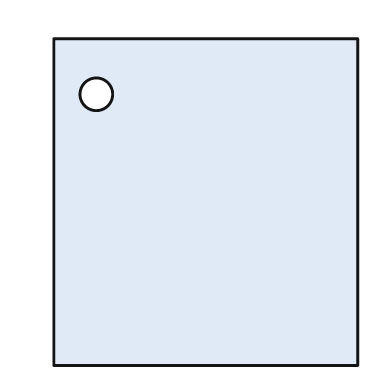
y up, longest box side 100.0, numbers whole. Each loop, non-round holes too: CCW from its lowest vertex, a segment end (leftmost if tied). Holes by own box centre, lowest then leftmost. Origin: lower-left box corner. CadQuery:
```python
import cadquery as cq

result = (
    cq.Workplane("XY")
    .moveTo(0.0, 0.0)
    .lineTo(93.0, 0.0)
    .lineTo(93.0, 100.0)
    .lineTo(0.0, 100.0)
    .close()
    .moveTo(13.0, 83.0)
    .circle(5.0)
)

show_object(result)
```